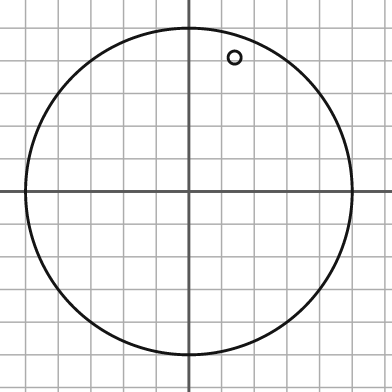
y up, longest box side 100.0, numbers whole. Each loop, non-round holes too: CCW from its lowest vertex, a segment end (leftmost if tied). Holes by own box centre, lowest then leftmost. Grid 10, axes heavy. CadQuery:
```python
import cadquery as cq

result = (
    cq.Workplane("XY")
    .moveTo(0.0, 0.0)
    .circle(50.0)
    .moveTo(14.0, 41.0)
    .circle(2.0)
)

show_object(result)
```